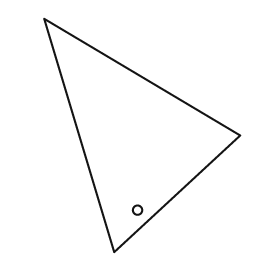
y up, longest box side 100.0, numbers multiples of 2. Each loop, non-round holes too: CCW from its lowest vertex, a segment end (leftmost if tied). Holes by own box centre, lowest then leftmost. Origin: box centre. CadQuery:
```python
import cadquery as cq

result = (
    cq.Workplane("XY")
    .moveTo(-12.0, -50.0)
    .lineTo(42.0, 0.0)
    .lineTo(-42.0, 50.0)
    .close()
    .moveTo(-2.0, -32.0)
    .circle(2.0)
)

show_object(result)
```